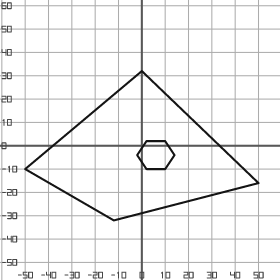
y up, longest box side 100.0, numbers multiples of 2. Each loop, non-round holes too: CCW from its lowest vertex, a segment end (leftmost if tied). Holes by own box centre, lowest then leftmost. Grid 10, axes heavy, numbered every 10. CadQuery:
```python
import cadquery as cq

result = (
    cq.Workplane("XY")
    .moveTo(-12.0, -32.0)
    .lineTo(50.0, -16.0)
    .lineTo(0.0, 32.0)
    .lineTo(-50.0, -10.0)
    .close()
    .moveTo(2.0, -10.0)
    .lineTo(10.0, -10.0)
    .lineTo(14.0, -4.0)
    .lineTo(10.0, 2.0)
    .lineTo(2.0, 2.0)
    .lineTo(-2.0, -4.0)
    .close()
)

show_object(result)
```